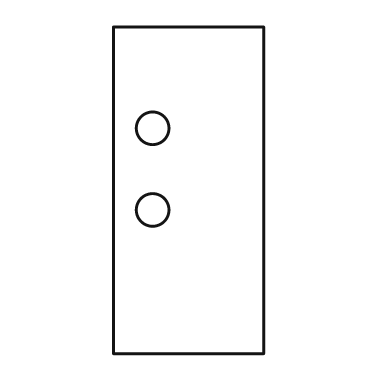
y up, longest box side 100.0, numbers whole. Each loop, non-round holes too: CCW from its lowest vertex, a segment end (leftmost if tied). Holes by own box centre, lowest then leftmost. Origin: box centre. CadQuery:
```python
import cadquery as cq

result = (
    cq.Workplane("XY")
    .moveTo(-23.0, -50.0)
    .lineTo(23.0, -50.0)
    .lineTo(23.0, 50.0)
    .lineTo(-23.0, 50.0)
    .close()
    .moveTo(-11.0, -6.0)
    .circle(5.0)
    .moveTo(-11.0, 19.0)
    .circle(5.0)
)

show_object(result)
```